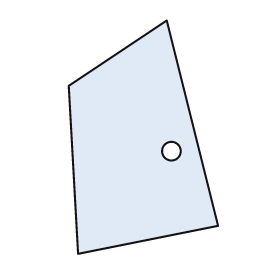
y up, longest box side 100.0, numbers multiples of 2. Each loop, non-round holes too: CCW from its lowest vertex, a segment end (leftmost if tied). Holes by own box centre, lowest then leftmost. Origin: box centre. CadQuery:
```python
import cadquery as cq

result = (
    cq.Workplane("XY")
    .moveTo(-28.0, -50.0)
    .lineTo(32.0, -38.0)
    .lineTo(10.0, 50.0)
    .lineTo(-32.0, 22.0)
    .close()
    .moveTo(12.0, -6.0)
    .circle(4.0)
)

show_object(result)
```